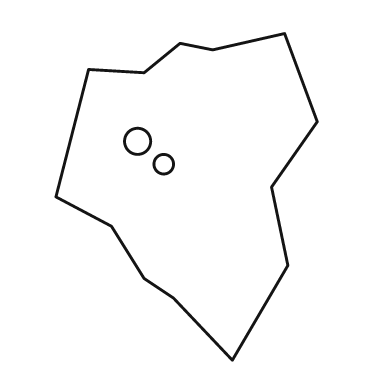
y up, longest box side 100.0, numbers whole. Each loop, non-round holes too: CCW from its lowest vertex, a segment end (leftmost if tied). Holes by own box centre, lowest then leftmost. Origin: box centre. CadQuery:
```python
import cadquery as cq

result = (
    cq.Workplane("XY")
    .moveTo(14.0, -50.0)
    .lineTo(31.0, -21.0)
    .lineTo(26.0, 3.0)
    .lineTo(40.0, 23.0)
    .lineTo(30.0, 50.0)
    .lineTo(8.0, 45.0)
    .lineTo(-2.0, 47.0)
    .lineTo(-13.0, 38.0)
    .lineTo(-30.0, 39.0)
    .lineTo(-40.0, 0.0)
    .lineTo(-23.0, -9.0)
    .lineTo(-13.0, -25.0)
    .lineTo(-4.0, -31.0)
    .close()
    .moveTo(-7.0, 10.0)
    .circle(3.0)
    .moveTo(-15.0, 17.0)
    .circle(4.0)
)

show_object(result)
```